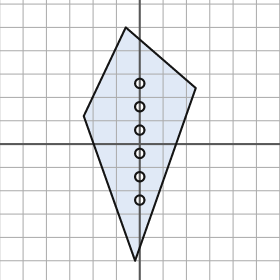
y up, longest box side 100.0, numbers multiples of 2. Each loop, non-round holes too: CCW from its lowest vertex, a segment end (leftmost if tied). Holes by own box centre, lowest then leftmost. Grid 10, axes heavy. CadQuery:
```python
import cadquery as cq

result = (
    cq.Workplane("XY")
    .moveTo(-2.0, -50.0)
    .lineTo(24.0, 24.0)
    .lineTo(-6.0, 50.0)
    .lineTo(-24.0, 12.0)
    .close()
    .moveTo(0.0, -24.0)
    .circle(2.0)
    .moveTo(0.0, -14.0)
    .circle(2.0)
    .moveTo(0.0, -4.0)
    .circle(2.0)
    .moveTo(0.0, 6.0)
    .circle(2.0)
    .moveTo(0.0, 16.0)
    .circle(2.0)
    .moveTo(0.0, 26.0)
    .circle(2.0)
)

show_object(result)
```